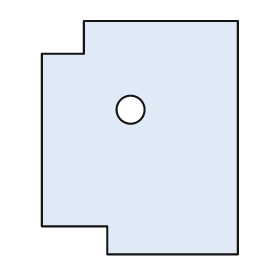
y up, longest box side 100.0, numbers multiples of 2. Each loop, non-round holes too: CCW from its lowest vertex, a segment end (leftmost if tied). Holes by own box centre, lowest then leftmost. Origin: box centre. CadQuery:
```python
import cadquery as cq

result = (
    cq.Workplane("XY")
    .moveTo(-14.0, -50.0)
    .lineTo(42.0, -50.0)
    .lineTo(42.0, 50.0)
    .lineTo(-24.0, 50.0)
    .lineTo(-24.0, 36.0)
    .lineTo(-42.0, 36.0)
    .lineTo(-42.0, -38.0)
    .lineTo(-14.0, -38.0)
    .close()
    .moveTo(-4.0, 12.0)
    .circle(6.0)
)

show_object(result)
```